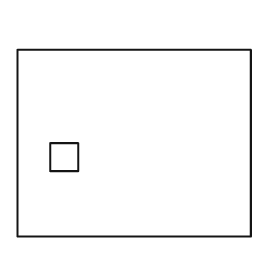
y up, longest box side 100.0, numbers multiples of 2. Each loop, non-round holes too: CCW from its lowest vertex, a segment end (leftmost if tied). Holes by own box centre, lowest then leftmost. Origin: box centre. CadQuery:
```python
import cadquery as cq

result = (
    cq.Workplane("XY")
    .moveTo(-50.0, -40.0)
    .lineTo(50.0, -40.0)
    .lineTo(50.0, 40.0)
    .lineTo(-50.0, 40.0)
    .close()
    .moveTo(-36.0, -12.0)
    .lineTo(-24.0, -12.0)
    .lineTo(-24.0, 0.0)
    .lineTo(-36.0, 0.0)
    .close()
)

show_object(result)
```